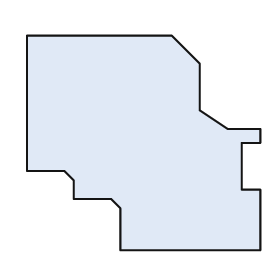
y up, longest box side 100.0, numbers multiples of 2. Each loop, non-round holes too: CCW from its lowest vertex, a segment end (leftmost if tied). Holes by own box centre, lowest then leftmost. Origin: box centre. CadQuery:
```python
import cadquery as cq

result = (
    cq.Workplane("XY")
    .moveTo(-10.0, -46.0)
    .lineTo(50.0, -46.0)
    .lineTo(50.0, -20.0)
    .lineTo(42.0, -20.0)
    .lineTo(42.0, 0.0)
    .lineTo(50.0, 0.0)
    .lineTo(50.0, 6.0)
    .lineTo(36.0, 6.0)
    .lineTo(24.0, 14.0)
    .lineTo(24.0, 34.0)
    .lineTo(12.0, 46.0)
    .lineTo(-50.0, 46.0)
    .lineTo(-50.0, -12.0)
    .lineTo(-34.0, -12.0)
    .lineTo(-30.0, -16.0)
    .lineTo(-30.0, -24.0)
    .lineTo(-14.0, -24.0)
    .lineTo(-10.0, -28.0)
    .close()
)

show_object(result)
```